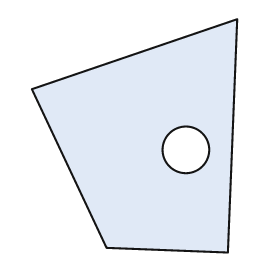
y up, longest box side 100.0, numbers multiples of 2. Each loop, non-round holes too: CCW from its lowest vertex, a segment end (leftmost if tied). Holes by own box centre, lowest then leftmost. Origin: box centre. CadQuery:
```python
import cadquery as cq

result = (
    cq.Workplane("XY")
    .moveTo(40.0, -50.0)
    .lineTo(44.0, 50.0)
    .lineTo(-44.0, 20.0)
    .lineTo(-12.0, -48.0)
    .close()
    .moveTo(22.0, -6.0)
    .circle(10.0)
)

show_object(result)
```